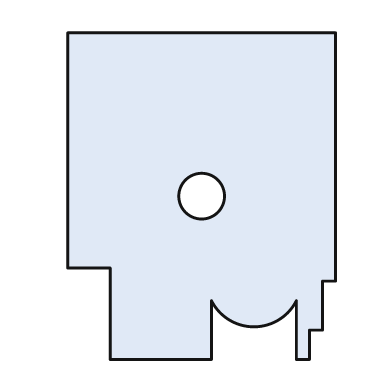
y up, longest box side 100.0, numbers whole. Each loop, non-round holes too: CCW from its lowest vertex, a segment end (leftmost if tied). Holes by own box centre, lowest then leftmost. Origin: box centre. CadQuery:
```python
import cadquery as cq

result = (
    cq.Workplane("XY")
    .moveTo(-28.0, -50.0)
    .lineTo(3.0, -50.0)
    .lineTo(3.0, -32.0)
    .threePointArc((16.0, -40.0), (29.0, -32.0))
    .lineTo(29.0, -50.0)
    .lineTo(33.0, -50.0)
    .lineTo(33.0, -41.0)
    .lineTo(37.0, -41.0)
    .lineTo(37.0, -26.0)
    .lineTo(41.0, -26.0)
    .lineTo(41.0, 50.0)
    .lineTo(-41.0, 50.0)
    .lineTo(-41.0, -22.0)
    .lineTo(-28.0, -22.0)
    .close()
    .moveTo(0.0, 0.0)
    .circle(7.0)
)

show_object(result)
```